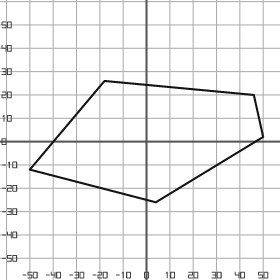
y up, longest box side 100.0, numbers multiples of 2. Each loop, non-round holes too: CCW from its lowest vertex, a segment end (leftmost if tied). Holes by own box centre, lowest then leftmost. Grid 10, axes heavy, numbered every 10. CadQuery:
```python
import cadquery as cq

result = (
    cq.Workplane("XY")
    .moveTo(4.0, -26.0)
    .lineTo(50.0, 2.0)
    .lineTo(46.0, 20.0)
    .lineTo(-18.0, 26.0)
    .lineTo(-50.0, -12.0)
    .close()
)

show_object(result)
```